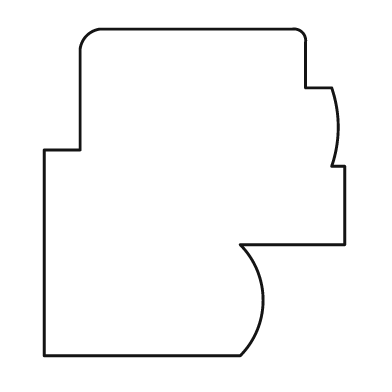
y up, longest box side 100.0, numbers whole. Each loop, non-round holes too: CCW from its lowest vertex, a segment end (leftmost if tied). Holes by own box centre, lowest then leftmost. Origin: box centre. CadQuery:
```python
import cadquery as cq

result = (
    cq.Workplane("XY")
    .moveTo(-46.0, -50.0)
    .lineTo(14.0, -50.0)
    .threePointArc((21.0, -33.0), (14.0, -16.0))
    .lineTo(46.0, -16.0)
    .lineTo(46.0, 8.0)
    .lineTo(42.0, 8.0)
    .threePointArc((44.0, 20.0), (42.0, 32.0))
    .lineTo(34.0, 32.0)
    .lineTo(34.0, 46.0)
    .threePointArc((33.0, 49.0), (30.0, 50.0))
    .lineTo(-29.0, 50.0)
    .threePointArc((-33.0, 48.0), (-35.0, 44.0))
    .lineTo(-35.0, 13.0)
    .lineTo(-46.0, 13.0)
    .close()
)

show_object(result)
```